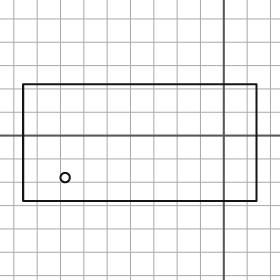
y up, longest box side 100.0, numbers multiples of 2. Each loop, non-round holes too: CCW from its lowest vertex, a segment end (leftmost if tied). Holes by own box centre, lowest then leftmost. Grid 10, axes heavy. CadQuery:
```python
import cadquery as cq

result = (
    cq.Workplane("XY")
    .moveTo(-86.0, -28.0)
    .lineTo(14.0, -28.0)
    .lineTo(14.0, 22.0)
    .lineTo(-86.0, 22.0)
    .close()
    .moveTo(-68.0, -18.0)
    .circle(2.0)
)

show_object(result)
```